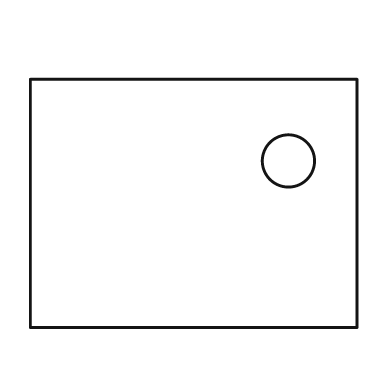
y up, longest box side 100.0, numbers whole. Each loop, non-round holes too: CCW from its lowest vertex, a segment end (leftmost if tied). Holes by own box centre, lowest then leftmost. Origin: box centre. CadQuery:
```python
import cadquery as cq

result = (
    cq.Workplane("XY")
    .moveTo(-50.0, -38.0)
    .lineTo(50.0, -38.0)
    .lineTo(50.0, 38.0)
    .lineTo(-50.0, 38.0)
    .close()
    .moveTo(29.0, 13.0)
    .circle(8.0)
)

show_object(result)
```